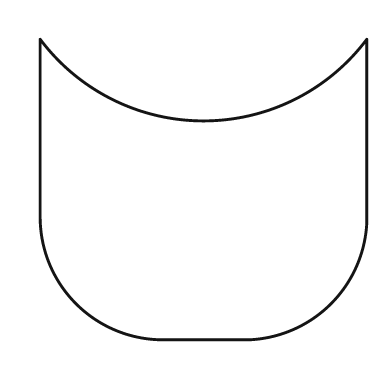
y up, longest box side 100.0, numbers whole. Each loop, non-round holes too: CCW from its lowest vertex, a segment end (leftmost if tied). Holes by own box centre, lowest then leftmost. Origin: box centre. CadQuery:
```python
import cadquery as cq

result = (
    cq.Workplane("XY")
    .moveTo(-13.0, -46.0)
    .lineTo(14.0, -46.0)
    .threePointArc((39.0, -35.0), (50.0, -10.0))
    .lineTo(50.0, 46.0)
    .threePointArc((0.0, 21.0), (-50.0, 46.0))
    .lineTo(-50.0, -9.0)
    .threePointArc((-39.0, -35.0), (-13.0, -46.0))
    .close()
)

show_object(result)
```